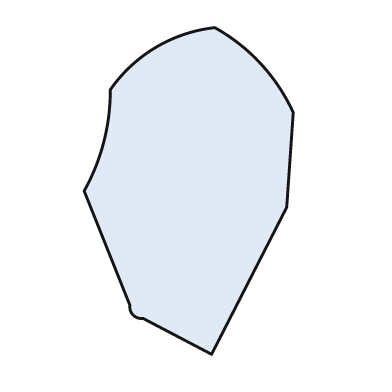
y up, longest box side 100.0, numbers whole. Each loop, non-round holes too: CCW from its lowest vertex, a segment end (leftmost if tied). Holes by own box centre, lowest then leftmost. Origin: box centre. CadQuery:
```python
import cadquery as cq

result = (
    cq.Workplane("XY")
    .moveTo(7.0, -50.0)
    .lineTo(30.0, -5.0)
    .lineTo(32.0, 24.0)
    .threePointArc((22.0, 39.0), (8.0, 50.0))
    .threePointArc((-10.0, 44.0), (-24.0, 31.0))
    .threePointArc((-26.0, 15.0), (-32.0, 0.0))
    .lineTo(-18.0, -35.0)
    .threePointArc((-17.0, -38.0), (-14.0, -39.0))
    .close()
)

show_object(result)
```